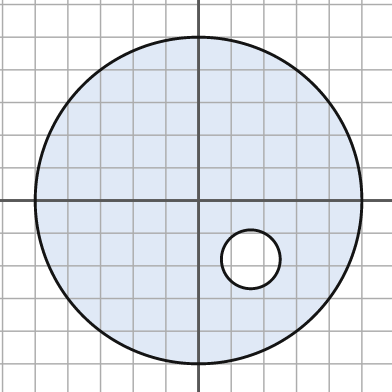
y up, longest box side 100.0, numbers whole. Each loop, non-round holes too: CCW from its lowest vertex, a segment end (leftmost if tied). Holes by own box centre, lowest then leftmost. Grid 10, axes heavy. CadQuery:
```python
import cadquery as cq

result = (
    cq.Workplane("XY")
    .moveTo(0.0, 0.0)
    .circle(50.0)
    .moveTo(16.0, -18.0)
    .circle(9.0)
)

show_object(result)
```